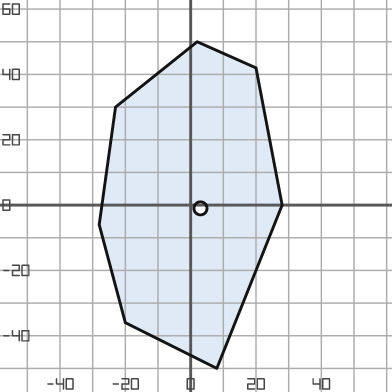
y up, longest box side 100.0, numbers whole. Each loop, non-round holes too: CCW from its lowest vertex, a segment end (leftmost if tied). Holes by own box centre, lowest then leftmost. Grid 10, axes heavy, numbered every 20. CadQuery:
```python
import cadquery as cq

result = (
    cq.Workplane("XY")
    .moveTo(8.0, -50.0)
    .lineTo(28.0, 0.0)
    .lineTo(20.0, 42.0)
    .lineTo(2.0, 50.0)
    .lineTo(-23.0, 30.0)
    .lineTo(-28.0, -6.0)
    .lineTo(-20.0, -36.0)
    .close()
    .moveTo(3.0, -1.0)
    .circle(2.0)
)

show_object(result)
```